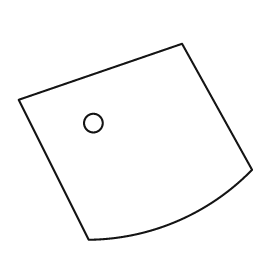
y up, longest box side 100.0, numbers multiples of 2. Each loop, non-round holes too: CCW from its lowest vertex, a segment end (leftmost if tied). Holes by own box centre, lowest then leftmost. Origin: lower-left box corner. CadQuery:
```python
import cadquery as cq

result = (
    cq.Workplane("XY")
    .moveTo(30.0, 0.0)
    .threePointArc((68.0, 8.0), (100.0, 30.0))
    .lineTo(70.0, 84.0)
    .lineTo(0.0, 60.0)
    .close()
    .moveTo(32.0, 50.0)
    .circle(4.0)
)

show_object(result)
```